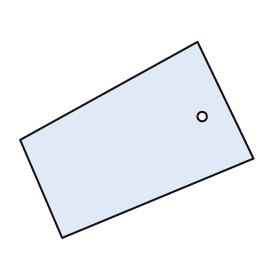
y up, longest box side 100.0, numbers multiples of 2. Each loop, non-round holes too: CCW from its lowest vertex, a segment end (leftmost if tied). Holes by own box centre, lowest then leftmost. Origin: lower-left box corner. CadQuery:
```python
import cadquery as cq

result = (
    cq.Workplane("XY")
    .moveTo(18.0, 0.0)
    .lineTo(100.0, 34.0)
    .lineTo(76.0, 84.0)
    .lineTo(0.0, 42.0)
    .close()
    .moveTo(78.0, 52.0)
    .circle(2.0)
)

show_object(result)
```